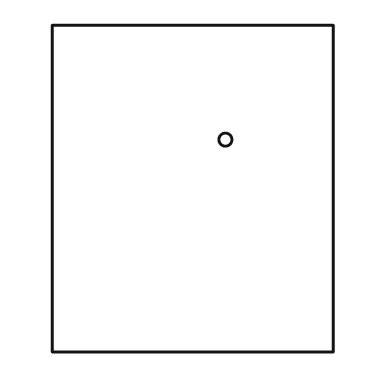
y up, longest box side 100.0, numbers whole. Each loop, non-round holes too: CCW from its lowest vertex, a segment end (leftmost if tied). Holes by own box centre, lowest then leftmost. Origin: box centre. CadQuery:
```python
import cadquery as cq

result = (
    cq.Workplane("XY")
    .moveTo(-43.0, -50.0)
    .lineTo(43.0, -50.0)
    .lineTo(43.0, 50.0)
    .lineTo(-43.0, 50.0)
    .close()
    .moveTo(10.0, 15.0)
    .circle(2.0)
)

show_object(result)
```